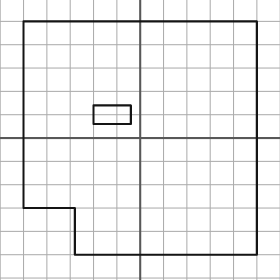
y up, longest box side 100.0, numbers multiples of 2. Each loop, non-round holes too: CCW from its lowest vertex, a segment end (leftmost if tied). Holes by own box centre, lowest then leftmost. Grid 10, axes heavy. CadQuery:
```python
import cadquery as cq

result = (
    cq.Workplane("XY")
    .moveTo(-28.0, -50.0)
    .lineTo(50.0, -50.0)
    .lineTo(50.0, 50.0)
    .lineTo(-50.0, 50.0)
    .lineTo(-50.0, -30.0)
    .lineTo(-28.0, -30.0)
    .close()
    .moveTo(-20.0, 6.0)
    .lineTo(-4.0, 6.0)
    .lineTo(-4.0, 14.0)
    .lineTo(-20.0, 14.0)
    .close()
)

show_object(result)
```